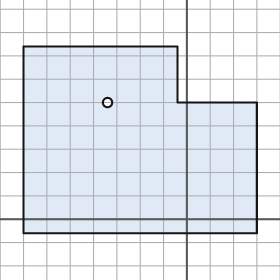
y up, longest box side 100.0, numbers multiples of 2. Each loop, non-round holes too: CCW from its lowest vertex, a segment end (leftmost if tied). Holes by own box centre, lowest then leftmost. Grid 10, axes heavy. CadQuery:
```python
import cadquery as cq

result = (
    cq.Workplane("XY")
    .moveTo(-70.0, -6.0)
    .lineTo(30.0, -6.0)
    .lineTo(30.0, 50.0)
    .lineTo(-4.0, 50.0)
    .lineTo(-4.0, 74.0)
    .lineTo(-70.0, 74.0)
    .close()
    .moveTo(-34.0, 50.0)
    .circle(2.0)
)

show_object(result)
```